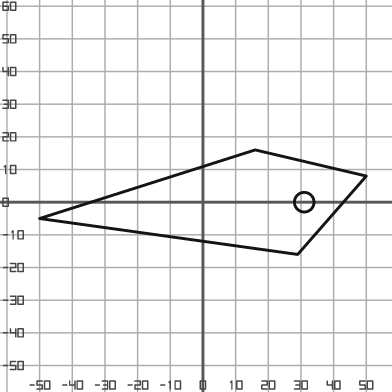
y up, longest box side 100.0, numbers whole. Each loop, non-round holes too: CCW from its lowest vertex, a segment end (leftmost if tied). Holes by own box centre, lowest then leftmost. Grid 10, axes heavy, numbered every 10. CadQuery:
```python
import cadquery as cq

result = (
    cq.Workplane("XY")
    .moveTo(29.0, -16.0)
    .lineTo(50.0, 8.0)
    .lineTo(16.0, 16.0)
    .lineTo(-50.0, -5.0)
    .close()
    .moveTo(31.0, 0.0)
    .circle(3.0)
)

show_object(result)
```